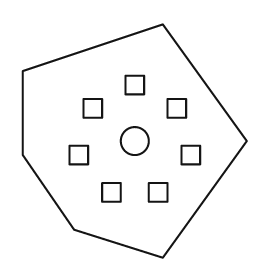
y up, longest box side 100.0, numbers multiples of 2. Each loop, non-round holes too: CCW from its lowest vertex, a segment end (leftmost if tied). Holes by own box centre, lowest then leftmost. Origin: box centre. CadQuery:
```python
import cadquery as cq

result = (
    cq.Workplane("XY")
    .moveTo(12.0, -50.0)
    .lineTo(48.0, 0.0)
    .lineTo(12.0, 50.0)
    .lineTo(-48.0, 30.0)
    .lineTo(-48.0, -6.0)
    .lineTo(-26.0, -38.0)
    .close()
    .moveTo(-14.0, -26.0)
    .lineTo(-6.0, -26.0)
    .lineTo(-6.0, -18.0)
    .lineTo(-14.0, -18.0)
    .close()
    .moveTo(6.0, -26.0)
    .lineTo(14.0, -26.0)
    .lineTo(14.0, -18.0)
    .lineTo(6.0, -18.0)
    .close()
    .moveTo(-28.0, -10.0)
    .lineTo(-20.0, -10.0)
    .lineTo(-20.0, -2.0)
    .lineTo(-28.0, -2.0)
    .close()
    .moveTo(20.0, -10.0)
    .lineTo(28.0, -10.0)
    .lineTo(28.0, -2.0)
    .lineTo(20.0, -2.0)
    .close()
    .moveTo(0.0, 0.0)
    .circle(6.0)
    .moveTo(-22.0, 10.0)
    .lineTo(-14.0, 10.0)
    .lineTo(-14.0, 18.0)
    .lineTo(-22.0, 18.0)
    .close()
    .moveTo(14.0, 10.0)
    .lineTo(22.0, 10.0)
    .lineTo(22.0, 18.0)
    .lineTo(14.0, 18.0)
    .close()
    .moveTo(-4.0, 20.0)
    .lineTo(4.0, 20.0)
    .lineTo(4.0, 28.0)
    .lineTo(-4.0, 28.0)
    .close()
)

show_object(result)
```